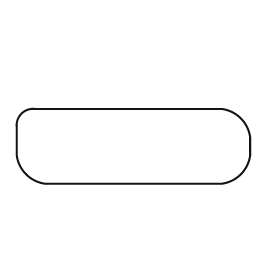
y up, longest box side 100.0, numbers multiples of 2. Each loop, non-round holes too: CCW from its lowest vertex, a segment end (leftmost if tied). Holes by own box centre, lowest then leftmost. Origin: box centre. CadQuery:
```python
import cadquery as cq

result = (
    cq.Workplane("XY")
    .moveTo(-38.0, -16.0)
    .lineTo(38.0, -16.0)
    .threePointArc((46.0, -12.0), (50.0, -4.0))
    .lineTo(50.0, 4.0)
    .threePointArc((46.0, 12.0), (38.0, 16.0))
    .lineTo(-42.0, 16.0)
    .threePointArc((-48.0, 14.0), (-50.0, 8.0))
    .lineTo(-50.0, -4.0)
    .threePointArc((-46.0, -12.0), (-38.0, -16.0))
    .close()
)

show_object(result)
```